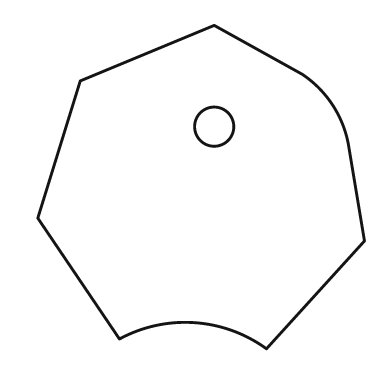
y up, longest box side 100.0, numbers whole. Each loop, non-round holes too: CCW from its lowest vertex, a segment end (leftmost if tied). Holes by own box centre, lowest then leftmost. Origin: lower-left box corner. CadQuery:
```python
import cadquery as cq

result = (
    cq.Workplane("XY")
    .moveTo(70.0, 0.0)
    .lineTo(100.0, 33.0)
    .lineTo(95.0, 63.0)
    .threePointArc((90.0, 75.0), (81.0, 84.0))
    .lineTo(54.0, 99.0)
    .lineTo(13.0, 82.0)
    .lineTo(0.0, 40.0)
    .lineTo(25.0, 3.0)
    .threePointArc((48.0, 8.0), (70.0, 0.0))
    .close()
    .moveTo(54.0, 68.0)
    .circle(6.0)
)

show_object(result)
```